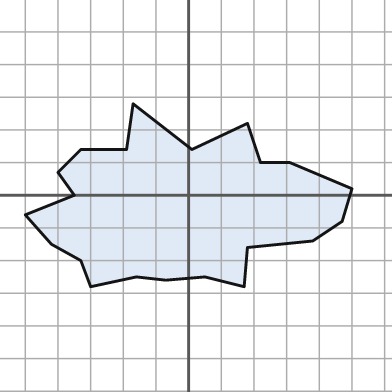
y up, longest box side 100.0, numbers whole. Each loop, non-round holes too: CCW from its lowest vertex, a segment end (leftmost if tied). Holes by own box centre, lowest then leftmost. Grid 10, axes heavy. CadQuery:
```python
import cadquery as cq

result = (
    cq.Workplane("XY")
    .moveTo(-30.0, -28.0)
    .lineTo(-16.0, -25.0)
    .lineTo(-7.0, -26.0)
    .lineTo(5.0, -25.0)
    .lineTo(17.0, -28.0)
    .lineTo(18.0, -16.0)
    .lineTo(38.0, -14.0)
    .lineTo(47.0, -8.0)
    .lineTo(50.0, 2.0)
    .lineTo(31.0, 10.0)
    .lineTo(22.0, 10.0)
    .lineTo(18.0, 22.0)
    .lineTo(1.0, 14.0)
    .lineTo(-17.0, 28.0)
    .lineTo(-19.0, 14.0)
    .lineTo(-33.0, 14.0)
    .lineTo(-40.0, 7.0)
    .lineTo(-35.0, 0.0)
    .lineTo(-50.0, -6.0)
    .lineTo(-42.0, -15.0)
    .lineTo(-33.0, -20.0)
    .close()
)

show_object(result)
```